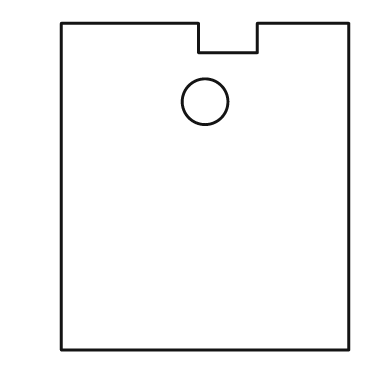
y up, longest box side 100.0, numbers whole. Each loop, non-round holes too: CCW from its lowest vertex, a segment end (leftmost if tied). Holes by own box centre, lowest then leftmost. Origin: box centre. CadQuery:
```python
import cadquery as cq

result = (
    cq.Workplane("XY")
    .moveTo(-44.0, -50.0)
    .lineTo(44.0, -50.0)
    .lineTo(44.0, 50.0)
    .lineTo(16.0, 50.0)
    .lineTo(16.0, 41.0)
    .lineTo(-2.0, 41.0)
    .lineTo(-2.0, 50.0)
    .lineTo(-44.0, 50.0)
    .close()
    .moveTo(0.0, 26.0)
    .circle(7.0)
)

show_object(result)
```